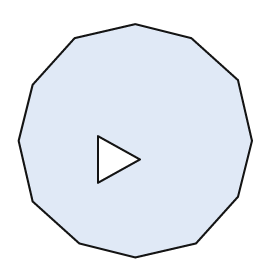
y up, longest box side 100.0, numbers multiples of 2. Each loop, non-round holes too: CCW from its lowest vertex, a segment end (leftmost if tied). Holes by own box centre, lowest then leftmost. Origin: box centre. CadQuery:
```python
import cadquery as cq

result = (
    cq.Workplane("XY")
    .moveTo(0.0, -50.0)
    .lineTo(26.0, -44.0)
    .lineTo(44.0, -24.0)
    .lineTo(50.0, 0.0)
    .lineTo(44.0, 26.0)
    .lineTo(24.0, 44.0)
    .lineTo(0.0, 50.0)
    .lineTo(-26.0, 44.0)
    .lineTo(-44.0, 24.0)
    .lineTo(-50.0, 0.0)
    .lineTo(-44.0, -26.0)
    .lineTo(-24.0, -44.0)
    .close()
    .moveTo(-16.0, -18.0)
    .lineTo(2.0, -8.0)
    .lineTo(-16.0, 2.0)
    .close()
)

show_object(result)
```